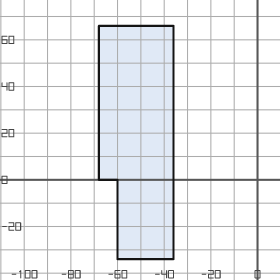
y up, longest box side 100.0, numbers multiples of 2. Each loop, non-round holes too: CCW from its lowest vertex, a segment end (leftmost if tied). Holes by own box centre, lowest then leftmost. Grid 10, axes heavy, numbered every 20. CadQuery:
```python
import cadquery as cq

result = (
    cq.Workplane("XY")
    .moveTo(-60.0, -34.0)
    .lineTo(-36.0, -34.0)
    .lineTo(-36.0, 66.0)
    .lineTo(-68.0, 66.0)
    .lineTo(-68.0, 0.0)
    .lineTo(-60.0, 0.0)
    .close()
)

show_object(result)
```